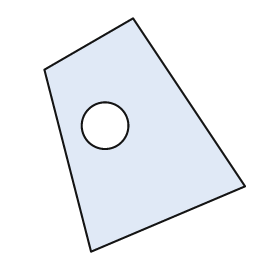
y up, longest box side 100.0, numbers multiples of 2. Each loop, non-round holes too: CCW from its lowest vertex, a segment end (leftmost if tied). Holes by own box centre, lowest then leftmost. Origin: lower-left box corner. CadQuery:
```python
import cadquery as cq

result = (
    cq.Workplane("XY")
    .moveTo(20.0, 0.0)
    .lineTo(86.0, 28.0)
    .lineTo(38.0, 100.0)
    .lineTo(0.0, 78.0)
    .close()
    .moveTo(26.0, 54.0)
    .circle(10.0)
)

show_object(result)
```